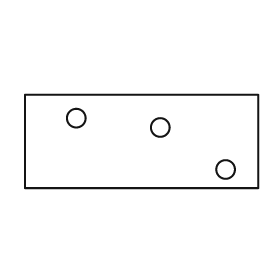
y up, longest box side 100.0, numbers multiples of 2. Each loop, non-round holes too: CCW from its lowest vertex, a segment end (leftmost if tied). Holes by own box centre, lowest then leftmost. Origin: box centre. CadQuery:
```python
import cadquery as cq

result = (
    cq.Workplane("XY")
    .moveTo(-50.0, -20.0)
    .lineTo(50.0, -20.0)
    .lineTo(50.0, 20.0)
    .lineTo(-50.0, 20.0)
    .close()
    .moveTo(36.0, -12.0)
    .circle(4.0)
    .moveTo(8.0, 6.0)
    .circle(4.0)
    .moveTo(-28.0, 10.0)
    .circle(4.0)
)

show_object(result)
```